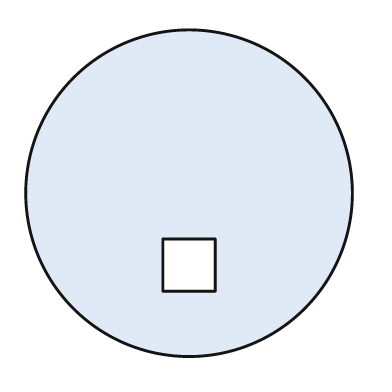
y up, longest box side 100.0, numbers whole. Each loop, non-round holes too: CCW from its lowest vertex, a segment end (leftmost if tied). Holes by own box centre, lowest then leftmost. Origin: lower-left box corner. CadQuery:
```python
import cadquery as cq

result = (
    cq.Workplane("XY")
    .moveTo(50.0, 50.0)
    .circle(50.0)
    .moveTo(42.0, 20.0)
    .lineTo(58.0, 20.0)
    .lineTo(58.0, 36.0)
    .lineTo(42.0, 36.0)
    .close()
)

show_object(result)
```